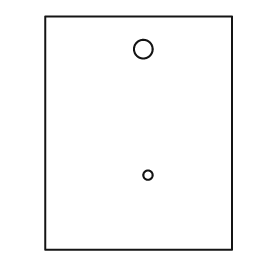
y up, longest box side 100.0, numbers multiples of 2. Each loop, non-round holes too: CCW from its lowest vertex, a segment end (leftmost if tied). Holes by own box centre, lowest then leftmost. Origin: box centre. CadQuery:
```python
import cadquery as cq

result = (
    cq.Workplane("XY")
    .moveTo(-40.0, -50.0)
    .lineTo(40.0, -50.0)
    .lineTo(40.0, 50.0)
    .lineTo(-40.0, 50.0)
    .close()
    .moveTo(4.0, -18.0)
    .circle(2.0)
    .moveTo(2.0, 36.0)
    .circle(4.0)
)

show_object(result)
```